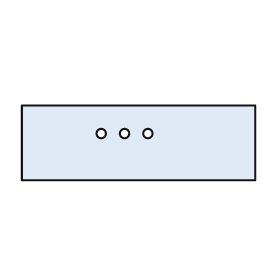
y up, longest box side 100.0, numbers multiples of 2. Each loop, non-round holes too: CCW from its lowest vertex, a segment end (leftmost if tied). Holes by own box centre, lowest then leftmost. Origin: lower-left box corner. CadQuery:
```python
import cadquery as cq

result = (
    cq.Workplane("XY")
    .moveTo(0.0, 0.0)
    .lineTo(100.0, 0.0)
    .lineTo(100.0, 32.0)
    .lineTo(0.0, 32.0)
    .close()
    .moveTo(34.0, 20.0)
    .circle(2.0)
    .moveTo(44.0, 20.0)
    .circle(2.0)
    .moveTo(54.0, 20.0)
    .circle(2.0)
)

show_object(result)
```